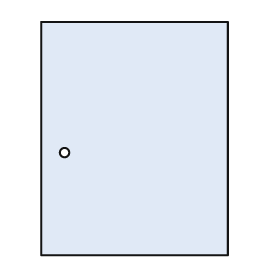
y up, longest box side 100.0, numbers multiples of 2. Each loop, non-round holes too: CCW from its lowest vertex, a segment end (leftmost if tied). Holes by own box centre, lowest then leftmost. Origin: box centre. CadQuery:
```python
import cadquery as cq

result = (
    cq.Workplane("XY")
    .moveTo(-40.0, -50.0)
    .lineTo(40.0, -50.0)
    .lineTo(40.0, 50.0)
    .lineTo(-40.0, 50.0)
    .close()
    .moveTo(-30.0, -6.0)
    .circle(2.0)
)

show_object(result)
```